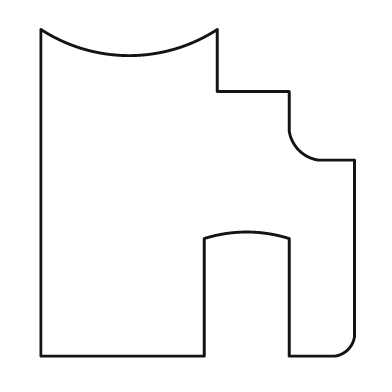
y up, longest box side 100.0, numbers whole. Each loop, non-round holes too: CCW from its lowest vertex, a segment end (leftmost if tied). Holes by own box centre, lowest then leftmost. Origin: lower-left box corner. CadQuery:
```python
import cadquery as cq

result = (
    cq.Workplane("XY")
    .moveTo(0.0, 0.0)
    .lineTo(50.0, 0.0)
    .lineTo(50.0, 36.0)
    .threePointArc((63.0, 38.0), (76.0, 36.0))
    .lineTo(76.0, 0.0)
    .lineTo(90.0, 0.0)
    .threePointArc((94.0, 2.0), (96.0, 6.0))
    .lineTo(96.0, 60.0)
    .lineTo(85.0, 60.0)
    .threePointArc((79.0, 63.0), (76.0, 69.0))
    .lineTo(76.0, 81.0)
    .lineTo(54.0, 81.0)
    .lineTo(54.0, 100.0)
    .threePointArc((27.0, 92.0), (0.0, 100.0))
    .close()
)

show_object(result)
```